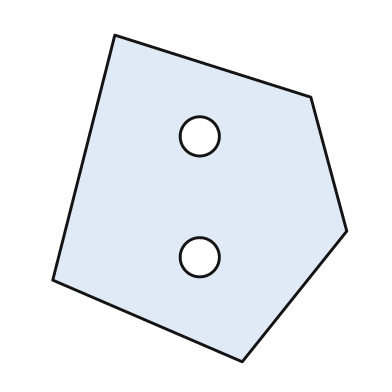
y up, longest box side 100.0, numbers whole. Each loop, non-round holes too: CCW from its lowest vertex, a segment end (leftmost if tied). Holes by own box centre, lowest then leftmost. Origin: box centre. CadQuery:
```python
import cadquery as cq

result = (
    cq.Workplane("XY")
    .moveTo(13.0, -50.0)
    .lineTo(45.0, -10.0)
    .lineTo(34.0, 31.0)
    .lineTo(-26.0, 50.0)
    .lineTo(-45.0, -25.0)
    .close()
    .moveTo(0.0, -18.0)
    .circle(6.0)
    .moveTo(0.0, 19.0)
    .circle(6.0)
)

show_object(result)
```